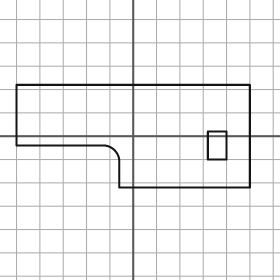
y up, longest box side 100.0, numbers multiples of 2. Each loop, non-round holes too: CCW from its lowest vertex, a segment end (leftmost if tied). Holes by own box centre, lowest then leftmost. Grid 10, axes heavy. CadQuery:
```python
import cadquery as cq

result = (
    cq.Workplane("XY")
    .moveTo(-6.0, -22.0)
    .lineTo(50.0, -22.0)
    .lineTo(50.0, 22.0)
    .lineTo(-50.0, 22.0)
    .lineTo(-50.0, -4.0)
    .lineTo(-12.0, -4.0)
    .threePointArc((-8.0, -6.0), (-6.0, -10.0))
    .close()
    .moveTo(32.0, -10.0)
    .lineTo(40.0, -10.0)
    .lineTo(40.0, 2.0)
    .lineTo(32.0, 2.0)
    .close()
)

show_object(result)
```